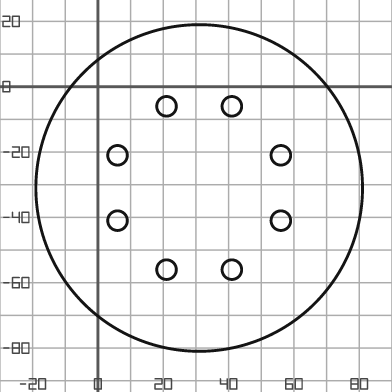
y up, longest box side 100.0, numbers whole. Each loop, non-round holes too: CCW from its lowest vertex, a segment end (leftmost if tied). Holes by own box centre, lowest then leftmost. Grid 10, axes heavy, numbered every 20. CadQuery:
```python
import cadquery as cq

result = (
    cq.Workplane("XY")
    .moveTo(31.0, -31.0)
    .circle(50.0)
    .moveTo(21.0, -56.0)
    .circle(3.0)
    .moveTo(41.0, -56.0)
    .circle(3.0)
    .moveTo(6.0, -41.0)
    .circle(3.0)
    .moveTo(56.0, -41.0)
    .circle(3.0)
    .moveTo(6.0, -21.0)
    .circle(3.0)
    .moveTo(56.0, -21.0)
    .circle(3.0)
    .moveTo(21.0, -6.0)
    .circle(3.0)
    .moveTo(41.0, -6.0)
    .circle(3.0)
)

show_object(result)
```